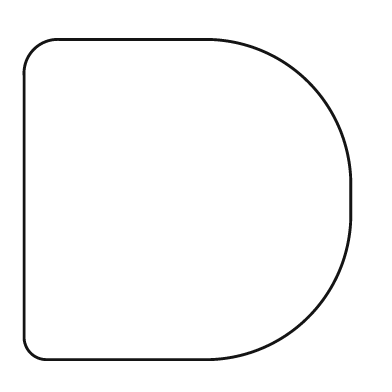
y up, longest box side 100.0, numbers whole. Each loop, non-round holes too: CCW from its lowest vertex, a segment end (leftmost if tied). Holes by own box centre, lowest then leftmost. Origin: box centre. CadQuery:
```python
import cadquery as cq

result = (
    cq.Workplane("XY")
    .moveTo(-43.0, -49.0)
    .lineTo(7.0, -49.0)
    .threePointArc((37.0, -36.0), (50.0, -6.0))
    .lineTo(50.0, 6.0)
    .threePointArc((37.0, 36.0), (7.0, 49.0))
    .lineTo(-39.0, 49.0)
    .threePointArc((-47.0, 46.0), (-50.0, 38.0))
    .lineTo(-50.0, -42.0)
    .threePointArc((-48.0, -47.0), (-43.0, -49.0))
    .close()
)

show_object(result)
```